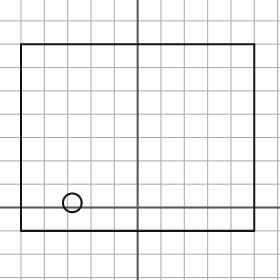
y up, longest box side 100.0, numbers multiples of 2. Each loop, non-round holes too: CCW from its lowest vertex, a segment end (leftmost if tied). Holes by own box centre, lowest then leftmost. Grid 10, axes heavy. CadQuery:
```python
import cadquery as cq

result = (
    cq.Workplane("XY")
    .moveTo(-50.0, -10.0)
    .lineTo(50.0, -10.0)
    .lineTo(50.0, 70.0)
    .lineTo(-50.0, 70.0)
    .close()
    .moveTo(-28.0, 2.0)
    .circle(4.0)
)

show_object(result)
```